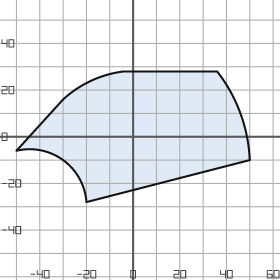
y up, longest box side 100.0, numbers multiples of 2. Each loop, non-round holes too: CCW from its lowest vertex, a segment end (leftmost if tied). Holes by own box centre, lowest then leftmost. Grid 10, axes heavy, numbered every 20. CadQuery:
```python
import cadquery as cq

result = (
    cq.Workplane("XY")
    .moveTo(-20.0, -28.0)
    .lineTo(50.0, -10.0)
    .threePointArc((46.0, 10.0), (36.0, 28.0))
    .lineTo(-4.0, 28.0)
    .threePointArc((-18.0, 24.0), (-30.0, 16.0))
    .lineTo(-50.0, -6.0)
    .threePointArc((-30.0, -10.0), (-20.0, -28.0))
    .close()
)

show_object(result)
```